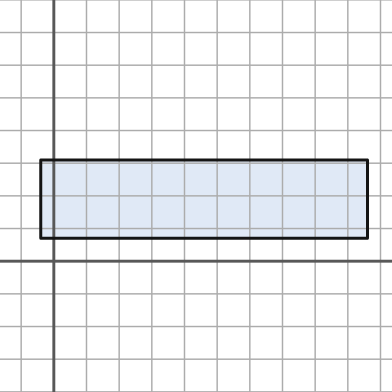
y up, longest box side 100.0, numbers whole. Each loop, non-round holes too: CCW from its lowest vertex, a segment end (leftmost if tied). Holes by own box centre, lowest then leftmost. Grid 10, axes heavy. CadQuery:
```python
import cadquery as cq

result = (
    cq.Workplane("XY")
    .moveTo(-4.0, 7.0)
    .lineTo(96.0, 7.0)
    .lineTo(96.0, 31.0)
    .lineTo(-4.0, 31.0)
    .close()
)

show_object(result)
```